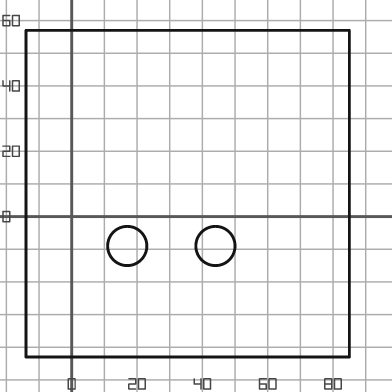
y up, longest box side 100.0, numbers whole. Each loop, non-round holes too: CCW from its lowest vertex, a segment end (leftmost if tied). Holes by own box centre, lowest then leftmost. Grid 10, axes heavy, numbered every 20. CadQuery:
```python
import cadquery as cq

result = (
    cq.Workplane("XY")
    .moveTo(-14.0, -43.0)
    .lineTo(85.0, -43.0)
    .lineTo(85.0, 57.0)
    .lineTo(-14.0, 57.0)
    .close()
    .moveTo(17.0, -9.0)
    .circle(6.0)
    .moveTo(44.0, -9.0)
    .circle(6.0)
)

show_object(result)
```